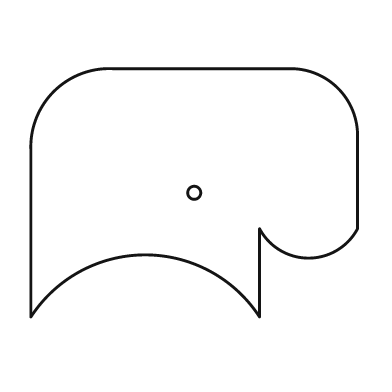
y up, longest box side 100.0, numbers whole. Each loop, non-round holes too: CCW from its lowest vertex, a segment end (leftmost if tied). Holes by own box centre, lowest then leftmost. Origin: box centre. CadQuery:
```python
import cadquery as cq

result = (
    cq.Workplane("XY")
    .moveTo(-50.0, -38.0)
    .threePointArc((-15.0, -19.0), (20.0, -38.0))
    .lineTo(20.0, -11.0)
    .threePointArc((35.0, -20.0), (50.0, -11.0))
    .lineTo(50.0, 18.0)
    .threePointArc((44.0, 32.0), (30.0, 38.0))
    .lineTo(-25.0, 38.0)
    .threePointArc((-43.0, 31.0), (-50.0, 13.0))
    .close()
    .moveTo(0.0, 0.0)
    .circle(2.0)
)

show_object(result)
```